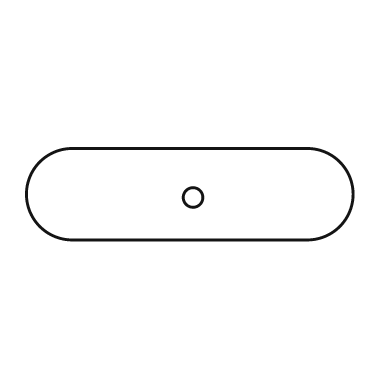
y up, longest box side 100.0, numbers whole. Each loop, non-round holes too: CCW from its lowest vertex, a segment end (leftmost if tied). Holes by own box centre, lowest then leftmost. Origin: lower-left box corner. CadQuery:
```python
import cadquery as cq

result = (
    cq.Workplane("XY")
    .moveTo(14.0, 0.0)
    .lineTo(86.0, 0.0)
    .threePointArc((100.0, 14.0), (86.0, 28.0))
    .lineTo(14.0, 28.0)
    .threePointArc((0.0, 14.0), (14.0, 0.0))
    .close()
    .moveTo(51.0, 13.0)
    .circle(3.0)
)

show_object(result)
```